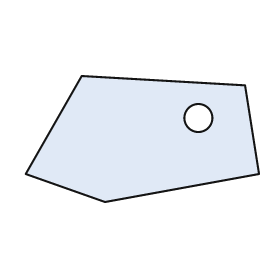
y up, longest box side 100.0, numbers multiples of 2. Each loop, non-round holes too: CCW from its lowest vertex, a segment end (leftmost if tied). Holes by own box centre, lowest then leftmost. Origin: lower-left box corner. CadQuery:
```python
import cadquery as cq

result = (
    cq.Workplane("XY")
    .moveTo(34.0, 0.0)
    .lineTo(100.0, 12.0)
    .lineTo(94.0, 50.0)
    .lineTo(24.0, 54.0)
    .lineTo(0.0, 12.0)
    .close()
    .moveTo(74.0, 36.0)
    .circle(6.0)
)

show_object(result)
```